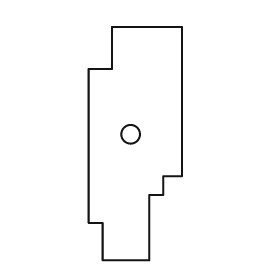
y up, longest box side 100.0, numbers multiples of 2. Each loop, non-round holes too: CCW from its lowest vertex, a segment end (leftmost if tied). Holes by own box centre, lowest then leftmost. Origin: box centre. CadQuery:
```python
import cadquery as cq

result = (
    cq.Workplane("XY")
    .moveTo(-14.0, -50.0)
    .lineTo(6.0, -50.0)
    .lineTo(6.0, -22.0)
    .lineTo(12.0, -22.0)
    .lineTo(12.0, -14.0)
    .lineTo(20.0, -14.0)
    .lineTo(20.0, 50.0)
    .lineTo(-10.0, 50.0)
    .lineTo(-10.0, 32.0)
    .lineTo(-20.0, 32.0)
    .lineTo(-20.0, -34.0)
    .lineTo(-14.0, -34.0)
    .close()
    .moveTo(-2.0, 4.0)
    .circle(4.0)
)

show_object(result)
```